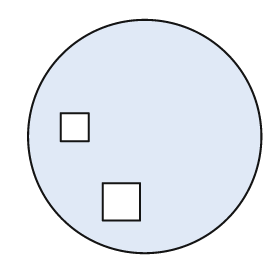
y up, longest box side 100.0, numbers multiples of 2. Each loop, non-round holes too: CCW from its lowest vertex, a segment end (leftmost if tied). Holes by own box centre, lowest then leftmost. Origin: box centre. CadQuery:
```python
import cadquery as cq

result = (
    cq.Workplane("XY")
    .moveTo(0.0, 0.0)
    .circle(50.0)
    .moveTo(-18.0, -36.0)
    .lineTo(-2.0, -36.0)
    .lineTo(-2.0, -20.0)
    .lineTo(-18.0, -20.0)
    .close()
    .moveTo(-36.0, -2.0)
    .lineTo(-24.0, -2.0)
    .lineTo(-24.0, 10.0)
    .lineTo(-36.0, 10.0)
    .close()
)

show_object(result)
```